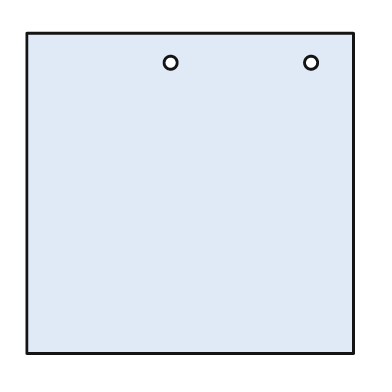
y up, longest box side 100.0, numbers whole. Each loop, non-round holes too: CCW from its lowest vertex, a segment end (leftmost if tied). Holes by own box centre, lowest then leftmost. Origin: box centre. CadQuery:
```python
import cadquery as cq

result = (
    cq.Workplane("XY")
    .moveTo(-50.0, -49.0)
    .lineTo(50.0, -49.0)
    .lineTo(50.0, 49.0)
    .lineTo(-50.0, 49.0)
    .close()
    .moveTo(-6.0, 40.0)
    .circle(2.0)
    .moveTo(37.0, 40.0)
    .circle(2.0)
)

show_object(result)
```